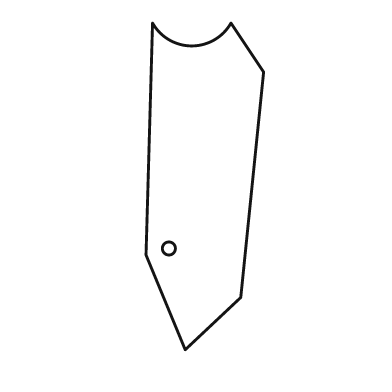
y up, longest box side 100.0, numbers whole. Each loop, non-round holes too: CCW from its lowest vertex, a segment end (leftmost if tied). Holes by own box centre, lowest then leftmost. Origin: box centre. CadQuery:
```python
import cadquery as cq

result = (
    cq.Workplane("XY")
    .moveTo(-6.0, -50.0)
    .lineTo(11.0, -34.0)
    .lineTo(18.0, 35.0)
    .lineTo(8.0, 50.0)
    .threePointArc((-4.0, 43.0), (-16.0, 50.0))
    .lineTo(-18.0, -21.0)
    .close()
    .moveTo(-11.0, -19.0)
    .circle(2.0)
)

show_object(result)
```